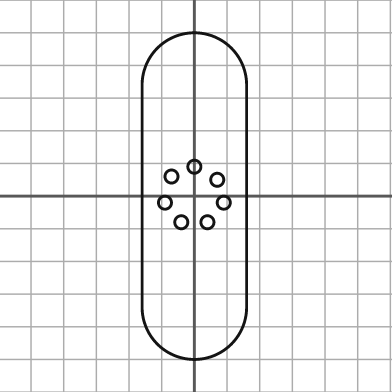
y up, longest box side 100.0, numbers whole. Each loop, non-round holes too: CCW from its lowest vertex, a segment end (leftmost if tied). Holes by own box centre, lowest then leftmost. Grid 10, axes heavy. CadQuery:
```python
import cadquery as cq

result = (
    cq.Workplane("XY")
    .moveTo(-16.0, -34.0)
    .threePointArc((0.0, -50.0), (16.0, -34.0))
    .lineTo(16.0, 34.0)
    .threePointArc((0.0, 50.0), (-16.0, 34.0))
    .close()
    .moveTo(-4.0, -8.0)
    .circle(2.0)
    .moveTo(4.0, -8.0)
    .circle(2.0)
    .moveTo(-9.0, -2.0)
    .circle(2.0)
    .moveTo(9.0, -2.0)
    .circle(2.0)
    .moveTo(7.0, 5.0)
    .circle(2.0)
    .moveTo(-7.0, 6.0)
    .circle(2.0)
    .moveTo(0.0, 9.0)
    .circle(2.0)
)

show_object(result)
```